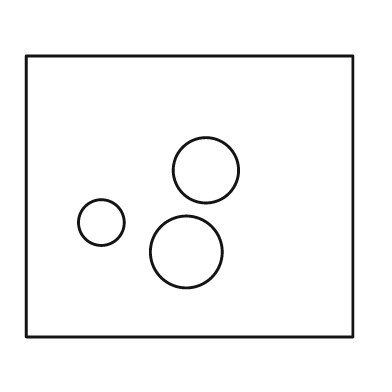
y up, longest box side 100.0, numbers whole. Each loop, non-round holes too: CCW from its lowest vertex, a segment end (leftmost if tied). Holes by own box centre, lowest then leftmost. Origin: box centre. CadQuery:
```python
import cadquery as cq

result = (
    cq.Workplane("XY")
    .moveTo(-50.0, -43.0)
    .lineTo(50.0, -43.0)
    .lineTo(50.0, 43.0)
    .lineTo(-50.0, 43.0)
    .close()
    .moveTo(-1.0, -17.0)
    .circle(11.0)
    .moveTo(-27.0, -8.0)
    .circle(7.0)
    .moveTo(5.0, 8.0)
    .circle(10.0)
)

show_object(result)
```